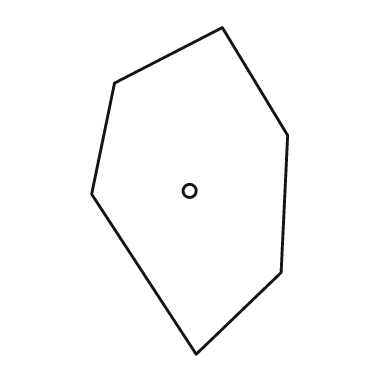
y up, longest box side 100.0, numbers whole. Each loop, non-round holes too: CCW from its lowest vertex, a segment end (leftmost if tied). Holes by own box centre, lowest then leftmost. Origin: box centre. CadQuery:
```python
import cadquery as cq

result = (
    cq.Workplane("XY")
    .moveTo(2.0, -50.0)
    .lineTo(28.0, -25.0)
    .lineTo(30.0, 17.0)
    .lineTo(10.0, 50.0)
    .lineTo(-23.0, 33.0)
    .lineTo(-30.0, -1.0)
    .close()
    .moveTo(0.0, 0.0)
    .circle(2.0)
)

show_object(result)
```